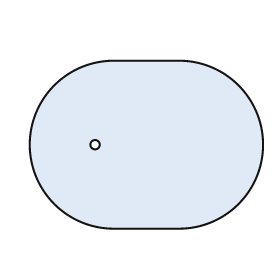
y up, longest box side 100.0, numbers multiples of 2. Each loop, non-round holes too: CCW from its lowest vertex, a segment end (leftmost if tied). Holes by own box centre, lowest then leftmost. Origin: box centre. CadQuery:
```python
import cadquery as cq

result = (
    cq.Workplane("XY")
    .moveTo(-14.0, -36.0)
    .lineTo(14.0, -36.0)
    .threePointArc((50.0, 0.0), (14.0, 36.0))
    .lineTo(-14.0, 36.0)
    .threePointArc((-50.0, 0.0), (-14.0, -36.0))
    .close()
    .moveTo(-22.0, 0.0)
    .circle(2.0)
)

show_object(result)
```